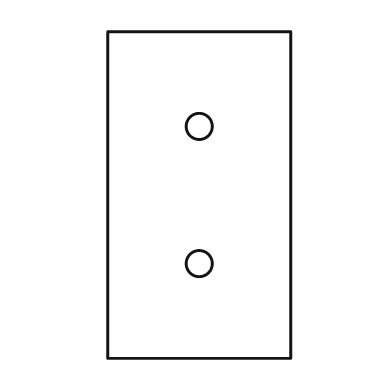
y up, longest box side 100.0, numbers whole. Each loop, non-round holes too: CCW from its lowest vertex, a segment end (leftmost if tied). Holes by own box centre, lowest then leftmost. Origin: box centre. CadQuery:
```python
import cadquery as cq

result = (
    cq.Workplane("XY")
    .moveTo(-28.0, -50.0)
    .lineTo(28.0, -50.0)
    .lineTo(28.0, 50.0)
    .lineTo(-28.0, 50.0)
    .close()
    .moveTo(0.0, -21.0)
    .circle(4.0)
    .moveTo(0.0, 21.0)
    .circle(4.0)
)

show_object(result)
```